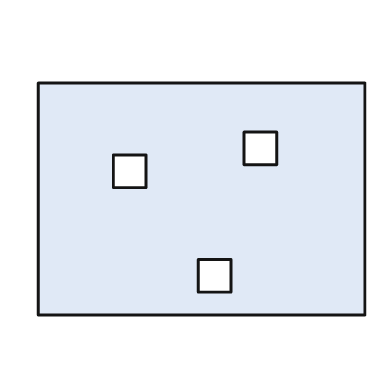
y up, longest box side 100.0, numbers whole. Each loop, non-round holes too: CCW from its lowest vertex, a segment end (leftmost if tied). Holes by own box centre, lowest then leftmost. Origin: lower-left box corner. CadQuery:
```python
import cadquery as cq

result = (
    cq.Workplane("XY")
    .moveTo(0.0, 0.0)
    .lineTo(100.0, 0.0)
    .lineTo(100.0, 71.0)
    .lineTo(0.0, 71.0)
    .close()
    .moveTo(49.0, 7.0)
    .lineTo(59.0, 7.0)
    .lineTo(59.0, 17.0)
    .lineTo(49.0, 17.0)
    .close()
    .moveTo(23.0, 39.0)
    .lineTo(33.0, 39.0)
    .lineTo(33.0, 49.0)
    .lineTo(23.0, 49.0)
    .close()
    .moveTo(63.0, 46.0)
    .lineTo(73.0, 46.0)
    .lineTo(73.0, 56.0)
    .lineTo(63.0, 56.0)
    .close()
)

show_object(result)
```